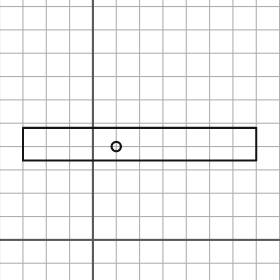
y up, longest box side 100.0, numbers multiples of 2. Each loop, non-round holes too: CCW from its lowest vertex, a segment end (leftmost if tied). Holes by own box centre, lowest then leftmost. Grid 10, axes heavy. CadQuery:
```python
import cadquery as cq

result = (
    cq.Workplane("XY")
    .moveTo(-30.0, 34.0)
    .lineTo(70.0, 34.0)
    .lineTo(70.0, 48.0)
    .lineTo(-30.0, 48.0)
    .close()
    .moveTo(10.0, 40.0)
    .circle(2.0)
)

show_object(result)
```